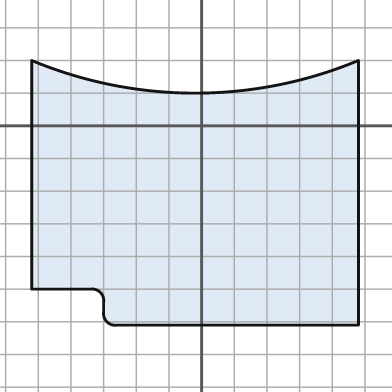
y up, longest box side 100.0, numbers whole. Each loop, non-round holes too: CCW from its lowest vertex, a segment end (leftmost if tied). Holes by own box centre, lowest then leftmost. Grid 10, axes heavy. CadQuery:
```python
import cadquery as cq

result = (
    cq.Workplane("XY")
    .moveTo(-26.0, -61.0)
    .lineTo(48.0, -61.0)
    .lineTo(48.0, 20.0)
    .threePointArc((-2.0, 10.0), (-52.0, 20.0))
    .lineTo(-52.0, -50.0)
    .lineTo(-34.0, -50.0)
    .threePointArc((-31.0, -51.0), (-30.0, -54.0))
    .lineTo(-30.0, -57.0)
    .threePointArc((-29.0, -60.0), (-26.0, -61.0))
    .close()
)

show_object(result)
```